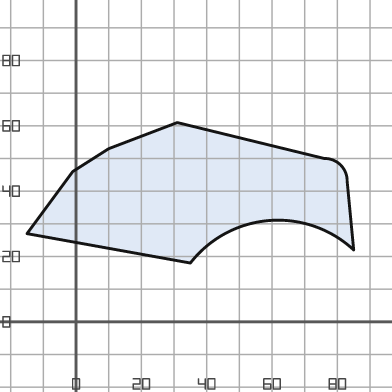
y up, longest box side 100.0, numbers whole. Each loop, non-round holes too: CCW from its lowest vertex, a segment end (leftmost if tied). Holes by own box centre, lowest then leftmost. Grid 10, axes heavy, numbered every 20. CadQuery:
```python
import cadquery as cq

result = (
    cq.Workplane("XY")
    .moveTo(35.0, 18.0)
    .threePointArc((59.0, 31.0), (85.0, 22.0))
    .lineTo(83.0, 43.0)
    .threePointArc((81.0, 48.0), (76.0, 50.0))
    .lineTo(31.0, 61.0)
    .lineTo(10.0, 53.0)
    .lineTo(-1.0, 46.0)
    .lineTo(-15.0, 27.0)
    .close()
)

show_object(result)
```